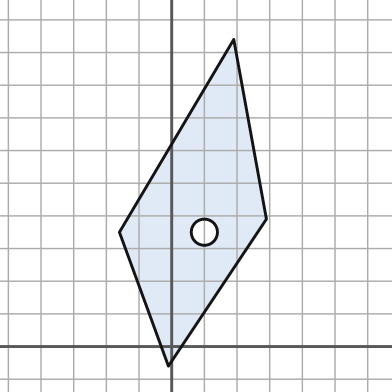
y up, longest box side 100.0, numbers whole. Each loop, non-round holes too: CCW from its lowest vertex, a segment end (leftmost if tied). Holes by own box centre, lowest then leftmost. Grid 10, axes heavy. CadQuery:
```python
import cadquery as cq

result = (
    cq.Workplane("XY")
    .moveTo(-1.0, -6.0)
    .lineTo(29.0, 39.0)
    .lineTo(19.0, 94.0)
    .lineTo(-16.0, 35.0)
    .close()
    .moveTo(10.0, 35.0)
    .circle(4.0)
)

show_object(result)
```